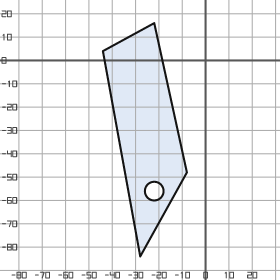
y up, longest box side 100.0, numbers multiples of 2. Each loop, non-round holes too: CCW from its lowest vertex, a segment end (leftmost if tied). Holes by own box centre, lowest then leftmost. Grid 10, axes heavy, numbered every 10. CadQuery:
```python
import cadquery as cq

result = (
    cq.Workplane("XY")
    .moveTo(-28.0, -84.0)
    .lineTo(-8.0, -48.0)
    .lineTo(-22.0, 16.0)
    .lineTo(-44.0, 4.0)
    .close()
    .moveTo(-22.0, -56.0)
    .circle(4.0)
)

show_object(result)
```